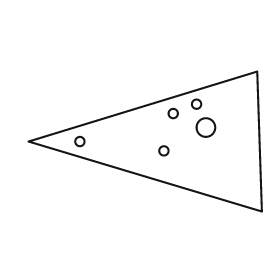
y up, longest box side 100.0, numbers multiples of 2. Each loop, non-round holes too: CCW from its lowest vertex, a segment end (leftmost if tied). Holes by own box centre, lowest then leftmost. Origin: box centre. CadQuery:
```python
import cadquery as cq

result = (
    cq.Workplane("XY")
    .moveTo(50.0, -30.0)
    .lineTo(48.0, 30.0)
    .lineTo(-50.0, 0.0)
    .close()
    .moveTo(8.0, -4.0)
    .circle(2.0)
    .moveTo(-28.0, 0.0)
    .circle(2.0)
    .moveTo(26.0, 6.0)
    .circle(4.0)
    .moveTo(12.0, 12.0)
    .circle(2.0)
    .moveTo(22.0, 16.0)
    .circle(2.0)
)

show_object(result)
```